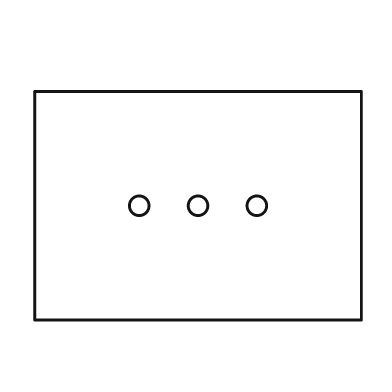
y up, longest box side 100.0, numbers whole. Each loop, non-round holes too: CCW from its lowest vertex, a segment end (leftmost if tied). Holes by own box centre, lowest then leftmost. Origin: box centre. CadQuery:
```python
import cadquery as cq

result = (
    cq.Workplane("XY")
    .moveTo(-50.0, -35.0)
    .lineTo(50.0, -35.0)
    .lineTo(50.0, 35.0)
    .lineTo(-50.0, 35.0)
    .close()
    .moveTo(-18.0, 0.0)
    .circle(3.0)
    .moveTo(0.0, 0.0)
    .circle(3.0)
    .moveTo(18.0, 0.0)
    .circle(3.0)
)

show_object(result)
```